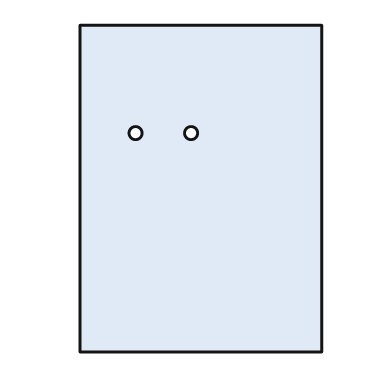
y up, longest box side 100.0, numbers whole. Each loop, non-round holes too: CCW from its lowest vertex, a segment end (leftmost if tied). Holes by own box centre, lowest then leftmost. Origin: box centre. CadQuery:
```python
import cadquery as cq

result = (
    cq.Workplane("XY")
    .moveTo(-37.0, -50.0)
    .lineTo(37.0, -50.0)
    .lineTo(37.0, 50.0)
    .lineTo(-37.0, 50.0)
    .close()
    .moveTo(-20.0, 17.0)
    .circle(2.0)
    .moveTo(-3.0, 17.0)
    .circle(2.0)
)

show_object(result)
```